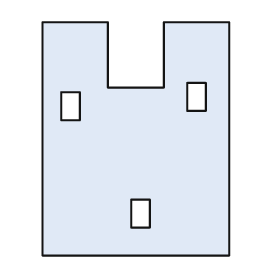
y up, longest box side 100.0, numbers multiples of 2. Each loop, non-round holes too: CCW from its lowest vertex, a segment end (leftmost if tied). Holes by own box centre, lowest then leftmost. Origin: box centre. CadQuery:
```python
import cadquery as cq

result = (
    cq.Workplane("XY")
    .moveTo(-40.0, -50.0)
    .lineTo(40.0, -50.0)
    .lineTo(40.0, 50.0)
    .lineTo(12.0, 50.0)
    .lineTo(12.0, 22.0)
    .lineTo(-12.0, 22.0)
    .lineTo(-12.0, 50.0)
    .lineTo(-40.0, 50.0)
    .close()
    .moveTo(-2.0, -38.0)
    .lineTo(6.0, -38.0)
    .lineTo(6.0, -26.0)
    .lineTo(-2.0, -26.0)
    .close()
    .moveTo(-32.0, 8.0)
    .lineTo(-24.0, 8.0)
    .lineTo(-24.0, 20.0)
    .lineTo(-32.0, 20.0)
    .close()
    .moveTo(22.0, 12.0)
    .lineTo(30.0, 12.0)
    .lineTo(30.0, 24.0)
    .lineTo(22.0, 24.0)
    .close()
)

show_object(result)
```